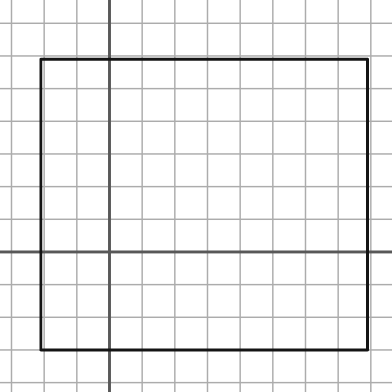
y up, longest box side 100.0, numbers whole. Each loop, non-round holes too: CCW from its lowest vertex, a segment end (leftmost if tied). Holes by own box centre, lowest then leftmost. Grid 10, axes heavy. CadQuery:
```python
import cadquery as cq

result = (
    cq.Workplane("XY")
    .moveTo(-21.0, -30.0)
    .lineTo(79.0, -30.0)
    .lineTo(79.0, 59.0)
    .lineTo(-21.0, 59.0)
    .close()
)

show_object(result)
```